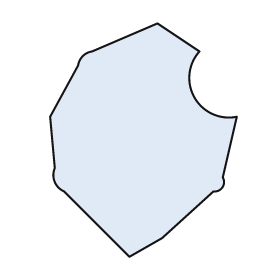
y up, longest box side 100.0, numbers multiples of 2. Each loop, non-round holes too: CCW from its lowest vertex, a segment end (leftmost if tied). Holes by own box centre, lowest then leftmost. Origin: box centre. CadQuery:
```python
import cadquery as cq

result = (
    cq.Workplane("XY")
    .moveTo(-6.0, -50.0)
    .lineTo(8.0, -42.0)
    .lineTo(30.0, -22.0)
    .threePointArc((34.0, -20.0), (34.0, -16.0))
    .lineTo(40.0, 10.0)
    .threePointArc((22.0, 18.0), (24.0, 38.0))
    .lineTo(6.0, 50.0)
    .lineTo(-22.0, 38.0)
    .threePointArc((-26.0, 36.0), (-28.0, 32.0))
    .lineTo(-40.0, 10.0)
    .lineTo(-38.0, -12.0)
    .threePointArc((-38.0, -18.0), (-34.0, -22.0))
    .close()
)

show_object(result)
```